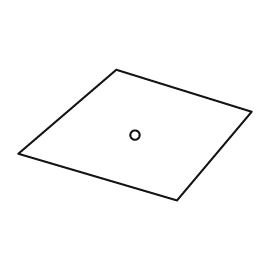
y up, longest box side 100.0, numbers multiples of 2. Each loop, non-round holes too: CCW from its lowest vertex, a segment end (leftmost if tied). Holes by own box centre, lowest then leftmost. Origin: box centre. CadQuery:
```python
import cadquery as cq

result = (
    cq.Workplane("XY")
    .moveTo(18.0, -28.0)
    .lineTo(50.0, 10.0)
    .lineTo(-8.0, 28.0)
    .lineTo(-50.0, -8.0)
    .close()
    .moveTo(0.0, 0.0)
    .circle(2.0)
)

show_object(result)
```